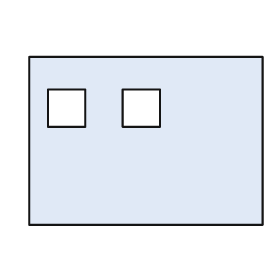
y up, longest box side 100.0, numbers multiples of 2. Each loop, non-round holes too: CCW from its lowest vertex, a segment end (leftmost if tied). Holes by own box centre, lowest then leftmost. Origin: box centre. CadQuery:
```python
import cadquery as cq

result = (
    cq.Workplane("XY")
    .moveTo(-50.0, -36.0)
    .lineTo(50.0, -36.0)
    .lineTo(50.0, 36.0)
    .lineTo(-50.0, 36.0)
    .close()
    .moveTo(-42.0, 6.0)
    .lineTo(-26.0, 6.0)
    .lineTo(-26.0, 22.0)
    .lineTo(-42.0, 22.0)
    .close()
    .moveTo(-10.0, 6.0)
    .lineTo(6.0, 6.0)
    .lineTo(6.0, 22.0)
    .lineTo(-10.0, 22.0)
    .close()
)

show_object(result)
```